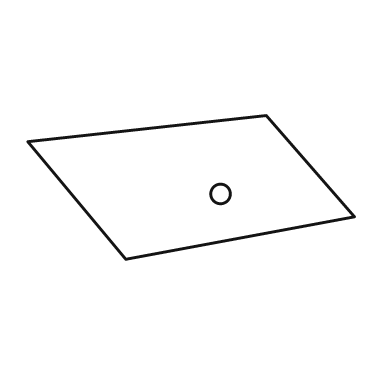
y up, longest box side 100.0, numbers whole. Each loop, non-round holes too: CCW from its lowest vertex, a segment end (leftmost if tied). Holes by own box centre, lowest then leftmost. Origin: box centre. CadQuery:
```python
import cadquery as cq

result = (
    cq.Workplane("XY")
    .moveTo(-20.0, -22.0)
    .lineTo(50.0, -9.0)
    .lineTo(23.0, 22.0)
    .lineTo(-50.0, 14.0)
    .close()
    .moveTo(9.0, -2.0)
    .circle(3.0)
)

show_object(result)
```